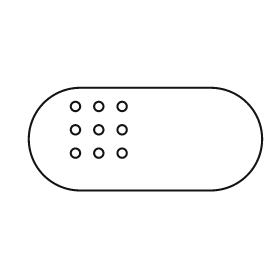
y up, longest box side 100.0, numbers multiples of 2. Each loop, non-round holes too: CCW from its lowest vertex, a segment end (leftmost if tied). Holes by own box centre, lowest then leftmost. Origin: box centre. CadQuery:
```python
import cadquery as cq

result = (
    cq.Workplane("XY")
    .moveTo(-28.0, -22.0)
    .lineTo(28.0, -22.0)
    .threePointArc((50.0, 0.0), (28.0, 22.0))
    .lineTo(-28.0, 22.0)
    .threePointArc((-50.0, 0.0), (-28.0, -22.0))
    .close()
    .moveTo(-30.0, -6.0)
    .circle(2.0)
    .moveTo(-20.0, -6.0)
    .circle(2.0)
    .moveTo(-10.0, -6.0)
    .circle(2.0)
    .moveTo(-30.0, 4.0)
    .circle(2.0)
    .moveTo(-20.0, 4.0)
    .circle(2.0)
    .moveTo(-10.0, 4.0)
    .circle(2.0)
    .moveTo(-30.0, 14.0)
    .circle(2.0)
    .moveTo(-20.0, 14.0)
    .circle(2.0)
    .moveTo(-10.0, 14.0)
    .circle(2.0)
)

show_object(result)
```